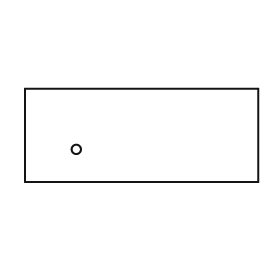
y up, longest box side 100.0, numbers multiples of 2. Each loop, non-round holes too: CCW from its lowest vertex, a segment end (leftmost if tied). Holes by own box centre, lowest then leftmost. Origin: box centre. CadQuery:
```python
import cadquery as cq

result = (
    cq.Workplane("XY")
    .moveTo(-50.0, -20.0)
    .lineTo(50.0, -20.0)
    .lineTo(50.0, 20.0)
    .lineTo(-50.0, 20.0)
    .close()
    .moveTo(-28.0, -6.0)
    .circle(2.0)
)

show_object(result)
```